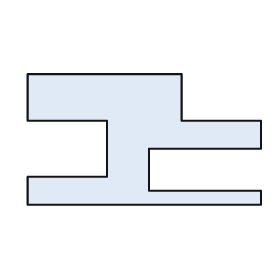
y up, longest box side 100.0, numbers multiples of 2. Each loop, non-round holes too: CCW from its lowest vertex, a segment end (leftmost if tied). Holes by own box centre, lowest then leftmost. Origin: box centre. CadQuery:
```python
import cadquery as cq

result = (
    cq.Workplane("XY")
    .moveTo(-50.0, -28.0)
    .lineTo(50.0, -28.0)
    .lineTo(50.0, -22.0)
    .lineTo(2.0, -22.0)
    .lineTo(2.0, -4.0)
    .lineTo(50.0, -4.0)
    .lineTo(50.0, 8.0)
    .lineTo(16.0, 8.0)
    .lineTo(16.0, 28.0)
    .lineTo(-50.0, 28.0)
    .lineTo(-50.0, 8.0)
    .lineTo(-16.0, 8.0)
    .lineTo(-16.0, -16.0)
    .lineTo(-50.0, -16.0)
    .close()
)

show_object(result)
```